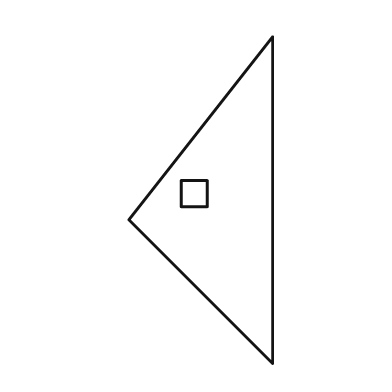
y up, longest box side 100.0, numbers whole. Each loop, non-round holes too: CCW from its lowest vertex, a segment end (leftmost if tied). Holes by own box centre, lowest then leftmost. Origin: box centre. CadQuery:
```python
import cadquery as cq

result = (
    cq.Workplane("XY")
    .moveTo(22.0, -50.0)
    .lineTo(22.0, 50.0)
    .lineTo(-22.0, -6.0)
    .close()
    .moveTo(-6.0, -2.0)
    .lineTo(2.0, -2.0)
    .lineTo(2.0, 6.0)
    .lineTo(-6.0, 6.0)
    .close()
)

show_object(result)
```